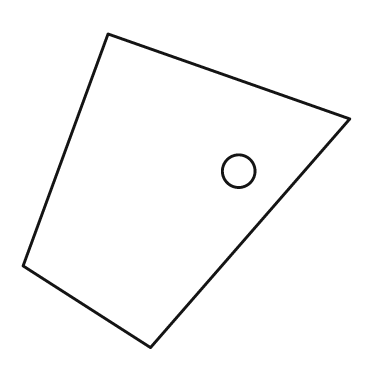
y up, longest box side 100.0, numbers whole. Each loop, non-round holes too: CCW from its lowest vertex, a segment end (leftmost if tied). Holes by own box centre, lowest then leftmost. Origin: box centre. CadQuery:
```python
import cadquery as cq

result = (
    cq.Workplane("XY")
    .moveTo(-11.0, -48.0)
    .lineTo(50.0, 22.0)
    .lineTo(-24.0, 48.0)
    .lineTo(-50.0, -23.0)
    .close()
    .moveTo(16.0, 6.0)
    .circle(5.0)
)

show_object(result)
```